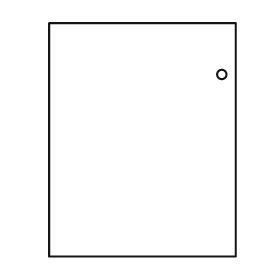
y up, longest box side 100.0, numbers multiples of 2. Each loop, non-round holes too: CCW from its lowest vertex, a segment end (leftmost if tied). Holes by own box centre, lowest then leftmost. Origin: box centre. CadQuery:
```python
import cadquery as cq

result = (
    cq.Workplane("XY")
    .moveTo(-40.0, -50.0)
    .lineTo(40.0, -50.0)
    .lineTo(40.0, 50.0)
    .lineTo(-40.0, 50.0)
    .close()
    .moveTo(34.0, 28.0)
    .circle(2.0)
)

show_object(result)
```